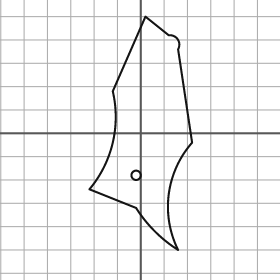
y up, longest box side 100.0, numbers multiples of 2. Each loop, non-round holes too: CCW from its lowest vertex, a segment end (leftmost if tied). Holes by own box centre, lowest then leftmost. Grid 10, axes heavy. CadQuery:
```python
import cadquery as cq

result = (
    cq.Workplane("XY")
    .moveTo(16.0, -50.0)
    .threePointArc((12.0, -26.0), (22.0, -4.0))
    .lineTo(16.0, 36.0)
    .threePointArc((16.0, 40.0), (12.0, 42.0))
    .lineTo(2.0, 50.0)
    .lineTo(-12.0, 18.0)
    .threePointArc((-12.0, -4.0), (-22.0, -24.0))
    .lineTo(-2.0, -32.0)
    .threePointArc((6.0, -42.0), (16.0, -50.0))
    .close()
    .moveTo(-2.0, -18.0)
    .circle(2.0)
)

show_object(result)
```